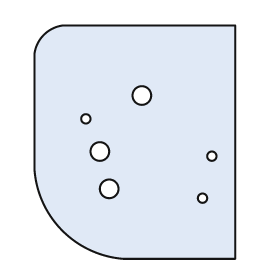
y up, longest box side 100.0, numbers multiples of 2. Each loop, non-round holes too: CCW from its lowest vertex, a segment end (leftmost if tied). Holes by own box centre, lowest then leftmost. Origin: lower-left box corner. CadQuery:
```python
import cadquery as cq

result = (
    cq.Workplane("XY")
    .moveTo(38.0, 0.0)
    .lineTo(86.0, 0.0)
    .lineTo(86.0, 100.0)
    .lineTo(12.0, 100.0)
    .threePointArc((4.0, 96.0), (0.0, 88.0))
    .lineTo(0.0, 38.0)
    .threePointArc((12.0, 12.0), (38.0, 0.0))
    .close()
    .moveTo(72.0, 26.0)
    .circle(2.0)
    .moveTo(32.0, 30.0)
    .circle(4.0)
    .moveTo(76.0, 44.0)
    .circle(2.0)
    .moveTo(28.0, 46.0)
    .circle(4.0)
    .moveTo(22.0, 60.0)
    .circle(2.0)
    .moveTo(46.0, 70.0)
    .circle(4.0)
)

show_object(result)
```